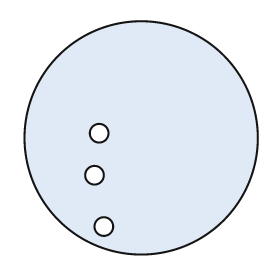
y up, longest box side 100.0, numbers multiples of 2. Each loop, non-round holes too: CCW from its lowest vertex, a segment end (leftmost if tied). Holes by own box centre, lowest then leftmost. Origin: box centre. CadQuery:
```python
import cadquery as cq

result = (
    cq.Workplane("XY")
    .moveTo(0.0, 0.0)
    .circle(50.0)
    .moveTo(-16.0, -38.0)
    .circle(4.0)
    .moveTo(-20.0, -16.0)
    .circle(4.0)
    .moveTo(-18.0, 2.0)
    .circle(4.0)
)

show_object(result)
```